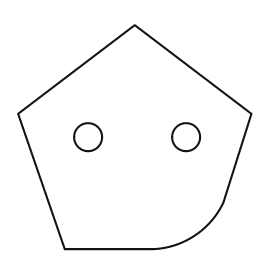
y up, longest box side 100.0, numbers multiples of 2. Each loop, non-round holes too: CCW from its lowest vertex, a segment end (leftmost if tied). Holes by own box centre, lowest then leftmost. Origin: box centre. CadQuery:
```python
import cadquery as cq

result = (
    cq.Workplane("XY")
    .moveTo(-30.0, -48.0)
    .lineTo(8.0, -48.0)
    .threePointArc((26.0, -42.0), (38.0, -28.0))
    .lineTo(50.0, 10.0)
    .lineTo(0.0, 48.0)
    .lineTo(-50.0, 10.0)
    .close()
    .moveTo(-20.0, 0.0)
    .circle(6.0)
    .moveTo(22.0, 0.0)
    .circle(6.0)
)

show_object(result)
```